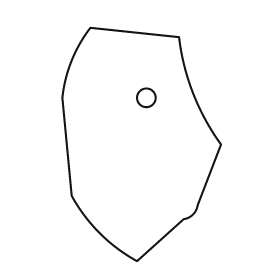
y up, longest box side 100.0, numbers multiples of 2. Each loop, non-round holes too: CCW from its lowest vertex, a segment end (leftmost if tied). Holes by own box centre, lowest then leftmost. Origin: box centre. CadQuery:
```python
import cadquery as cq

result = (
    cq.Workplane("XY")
    .moveTo(-2.0, -50.0)
    .lineTo(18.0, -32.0)
    .threePointArc((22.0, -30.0), (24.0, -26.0))
    .lineTo(34.0, 0.0)
    .threePointArc((22.0, 22.0), (16.0, 46.0))
    .lineTo(-22.0, 50.0)
    .threePointArc((-30.0, 36.0), (-34.0, 20.0))
    .lineTo(-30.0, -22.0)
    .threePointArc((-18.0, -38.0), (-2.0, -50.0))
    .close()
    .moveTo(2.0, 20.0)
    .circle(4.0)
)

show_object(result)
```